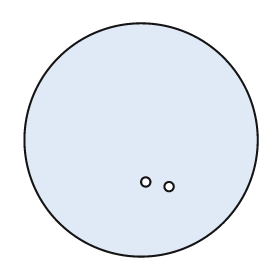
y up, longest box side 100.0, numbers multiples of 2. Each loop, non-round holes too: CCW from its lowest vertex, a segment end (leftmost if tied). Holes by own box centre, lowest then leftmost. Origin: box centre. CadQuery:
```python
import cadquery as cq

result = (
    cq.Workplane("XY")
    .moveTo(0.0, 0.0)
    .circle(50.0)
    .moveTo(12.0, -20.0)
    .circle(2.0)
    .moveTo(2.0, -18.0)
    .circle(2.0)
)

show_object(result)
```